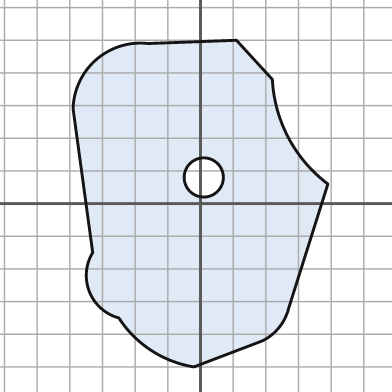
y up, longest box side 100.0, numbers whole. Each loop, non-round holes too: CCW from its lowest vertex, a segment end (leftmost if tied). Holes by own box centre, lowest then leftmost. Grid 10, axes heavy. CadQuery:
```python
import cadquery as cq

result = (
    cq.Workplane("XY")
    .moveTo(-2.0, -50.0)
    .lineTo(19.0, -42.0)
    .threePointArc((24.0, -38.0), (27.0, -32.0))
    .lineTo(39.0, 6.0)
    .threePointArc((27.0, 20.0), (22.0, 38.0))
    .lineTo(11.0, 50.0)
    .lineTo(-16.0, 49.0)
    .threePointArc((-32.0, 44.0), (-39.0, 29.0))
    .lineTo(-33.0, -15.0)
    .threePointArc((-34.0, -27.0), (-25.0, -35.0))
    .threePointArc((-15.0, -45.0), (-2.0, -50.0))
    .close()
    .moveTo(1.0, 8.0)
    .circle(6.0)
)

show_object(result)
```